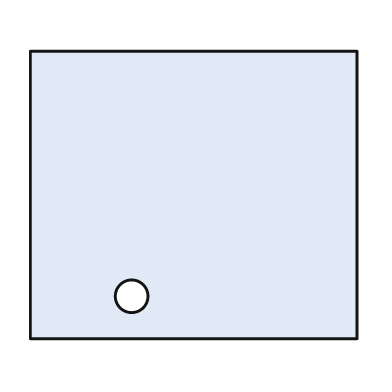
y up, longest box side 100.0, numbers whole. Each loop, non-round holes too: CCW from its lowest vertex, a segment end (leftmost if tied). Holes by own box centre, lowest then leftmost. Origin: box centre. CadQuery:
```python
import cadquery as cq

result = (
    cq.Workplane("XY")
    .moveTo(-50.0, -44.0)
    .lineTo(50.0, -44.0)
    .lineTo(50.0, 44.0)
    .lineTo(-50.0, 44.0)
    .close()
    .moveTo(-19.0, -31.0)
    .circle(5.0)
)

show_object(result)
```